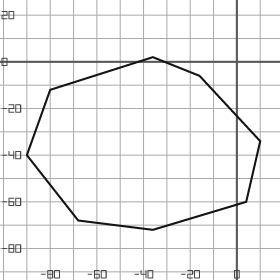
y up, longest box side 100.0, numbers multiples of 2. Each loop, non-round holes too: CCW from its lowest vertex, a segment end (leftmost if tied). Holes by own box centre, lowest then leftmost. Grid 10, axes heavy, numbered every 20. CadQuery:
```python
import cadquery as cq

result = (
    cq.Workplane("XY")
    .moveTo(-36.0, -72.0)
    .lineTo(4.0, -60.0)
    .lineTo(10.0, -34.0)
    .lineTo(-16.0, -6.0)
    .lineTo(-36.0, 2.0)
    .lineTo(-80.0, -12.0)
    .lineTo(-90.0, -40.0)
    .lineTo(-68.0, -68.0)
    .close()
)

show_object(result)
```